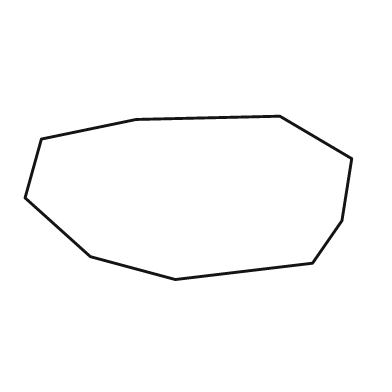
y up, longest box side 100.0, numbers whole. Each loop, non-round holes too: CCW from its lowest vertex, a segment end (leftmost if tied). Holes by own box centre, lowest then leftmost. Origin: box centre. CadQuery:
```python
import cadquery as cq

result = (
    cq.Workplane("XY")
    .moveTo(-4.0, -25.0)
    .lineTo(38.0, -20.0)
    .lineTo(47.0, -7.0)
    .lineTo(50.0, 12.0)
    .lineTo(28.0, 25.0)
    .lineTo(-16.0, 24.0)
    .lineTo(-45.0, 18.0)
    .lineTo(-50.0, 0.0)
    .lineTo(-30.0, -18.0)
    .close()
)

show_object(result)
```